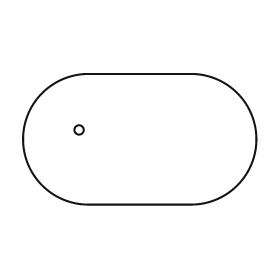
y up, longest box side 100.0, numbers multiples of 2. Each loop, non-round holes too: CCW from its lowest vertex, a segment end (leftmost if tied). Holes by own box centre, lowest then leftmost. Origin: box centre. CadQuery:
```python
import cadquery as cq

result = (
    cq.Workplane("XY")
    .moveTo(-22.0, -28.0)
    .lineTo(22.0, -28.0)
    .threePointArc((50.0, 0.0), (22.0, 28.0))
    .lineTo(-22.0, 28.0)
    .threePointArc((-50.0, 0.0), (-22.0, -28.0))
    .close()
    .moveTo(-26.0, 4.0)
    .circle(2.0)
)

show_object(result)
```